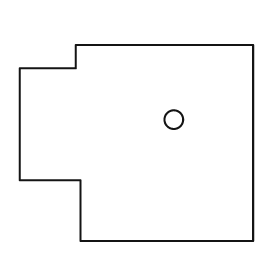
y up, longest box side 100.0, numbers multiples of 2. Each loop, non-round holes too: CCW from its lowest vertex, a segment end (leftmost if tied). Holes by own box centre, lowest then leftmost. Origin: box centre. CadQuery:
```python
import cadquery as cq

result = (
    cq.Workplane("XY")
    .moveTo(-24.0, -42.0)
    .lineTo(50.0, -42.0)
    .lineTo(50.0, 42.0)
    .lineTo(-26.0, 42.0)
    .lineTo(-26.0, 32.0)
    .lineTo(-50.0, 32.0)
    .lineTo(-50.0, -16.0)
    .lineTo(-24.0, -16.0)
    .close()
    .moveTo(16.0, 10.0)
    .circle(4.0)
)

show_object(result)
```